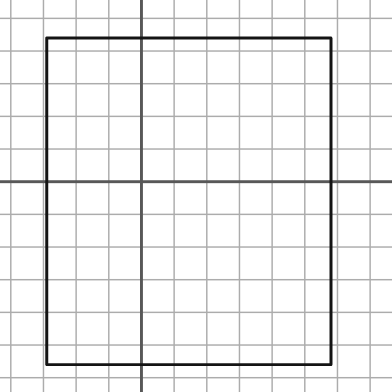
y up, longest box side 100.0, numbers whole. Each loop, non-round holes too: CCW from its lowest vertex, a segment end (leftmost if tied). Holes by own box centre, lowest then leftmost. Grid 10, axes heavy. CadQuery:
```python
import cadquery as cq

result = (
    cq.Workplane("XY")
    .moveTo(-29.0, -56.0)
    .lineTo(58.0, -56.0)
    .lineTo(58.0, 44.0)
    .lineTo(-29.0, 44.0)
    .close()
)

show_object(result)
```